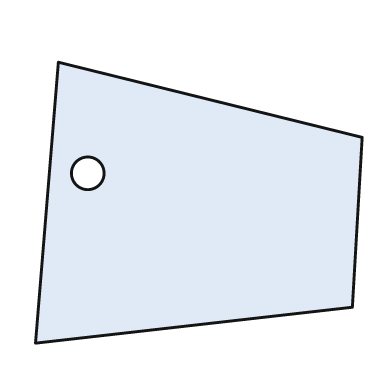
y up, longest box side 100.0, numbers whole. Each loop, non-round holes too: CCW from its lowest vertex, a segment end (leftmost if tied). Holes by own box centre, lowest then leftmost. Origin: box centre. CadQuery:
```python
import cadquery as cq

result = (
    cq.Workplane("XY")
    .moveTo(-50.0, -43.0)
    .lineTo(47.0, -32.0)
    .lineTo(50.0, 20.0)
    .lineTo(-43.0, 43.0)
    .close()
    .moveTo(-34.0, 9.0)
    .circle(5.0)
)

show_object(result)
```